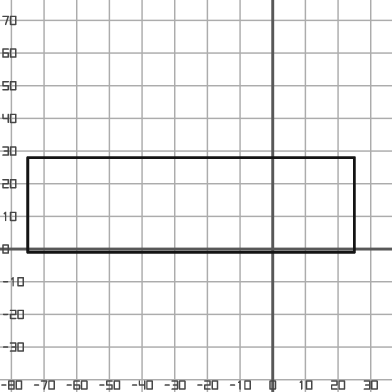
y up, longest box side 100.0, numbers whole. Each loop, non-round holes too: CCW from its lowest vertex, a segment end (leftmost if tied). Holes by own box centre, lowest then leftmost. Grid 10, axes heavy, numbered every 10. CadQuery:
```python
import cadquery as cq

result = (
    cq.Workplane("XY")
    .moveTo(-75.0, -1.0)
    .lineTo(25.0, -1.0)
    .lineTo(25.0, 28.0)
    .lineTo(-75.0, 28.0)
    .close()
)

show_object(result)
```